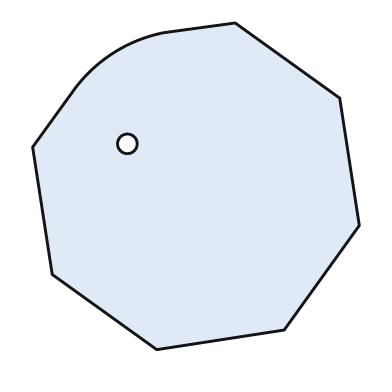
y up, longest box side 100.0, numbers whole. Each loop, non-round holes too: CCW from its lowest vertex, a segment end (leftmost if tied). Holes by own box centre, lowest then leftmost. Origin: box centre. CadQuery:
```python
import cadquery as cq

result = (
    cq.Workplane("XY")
    .moveTo(-12.0, -50.0)
    .lineTo(27.0, -44.0)
    .lineTo(50.0, -12.0)
    .lineTo(44.0, 27.0)
    .lineTo(12.0, 50.0)
    .lineTo(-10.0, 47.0)
    .threePointArc((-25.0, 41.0), (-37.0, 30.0))
    .lineTo(-50.0, 12.0)
    .lineTo(-44.0, -27.0)
    .close()
    .moveTo(-21.0, 13.0)
    .circle(3.0)
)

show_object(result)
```